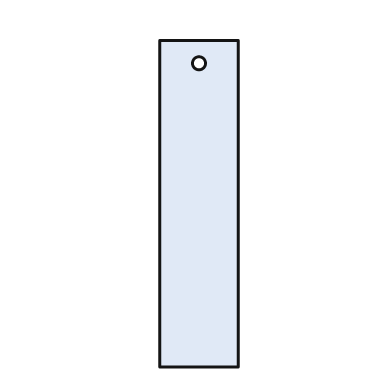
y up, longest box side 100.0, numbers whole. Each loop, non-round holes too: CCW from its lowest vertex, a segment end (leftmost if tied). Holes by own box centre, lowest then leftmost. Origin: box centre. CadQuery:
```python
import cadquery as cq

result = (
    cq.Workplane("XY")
    .moveTo(-12.0, -50.0)
    .lineTo(12.0, -50.0)
    .lineTo(12.0, 50.0)
    .lineTo(-12.0, 50.0)
    .close()
    .moveTo(0.0, 43.0)
    .circle(2.0)
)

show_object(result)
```